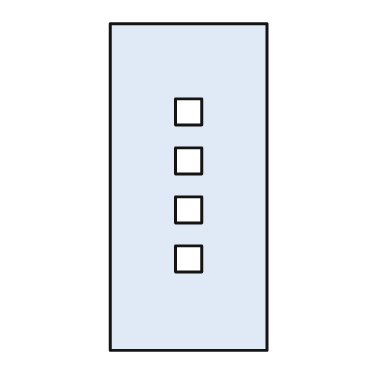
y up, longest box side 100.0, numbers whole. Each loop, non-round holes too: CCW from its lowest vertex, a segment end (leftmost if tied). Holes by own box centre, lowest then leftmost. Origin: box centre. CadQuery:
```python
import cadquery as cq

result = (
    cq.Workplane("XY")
    .moveTo(-24.0, -50.0)
    .lineTo(24.0, -50.0)
    .lineTo(24.0, 50.0)
    .lineTo(-24.0, 50.0)
    .close()
    .moveTo(-4.0, -26.0)
    .lineTo(4.0, -26.0)
    .lineTo(4.0, -18.0)
    .lineTo(-4.0, -18.0)
    .close()
    .moveTo(-4.0, -11.0)
    .lineTo(4.0, -11.0)
    .lineTo(4.0, -3.0)
    .lineTo(-4.0, -3.0)
    .close()
    .moveTo(-4.0, 4.0)
    .lineTo(4.0, 4.0)
    .lineTo(4.0, 12.0)
    .lineTo(-4.0, 12.0)
    .close()
    .moveTo(-4.0, 19.0)
    .lineTo(4.0, 19.0)
    .lineTo(4.0, 27.0)
    .lineTo(-4.0, 27.0)
    .close()
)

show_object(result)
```